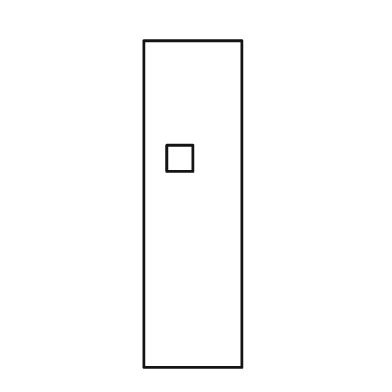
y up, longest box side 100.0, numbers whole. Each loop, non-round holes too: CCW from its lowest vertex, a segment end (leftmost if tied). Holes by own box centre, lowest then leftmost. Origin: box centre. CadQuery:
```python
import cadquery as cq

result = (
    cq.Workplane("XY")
    .moveTo(-15.0, -50.0)
    .lineTo(15.0, -50.0)
    .lineTo(15.0, 50.0)
    .lineTo(-15.0, 50.0)
    .close()
    .moveTo(-8.0, 10.0)
    .lineTo(0.0, 10.0)
    .lineTo(0.0, 18.0)
    .lineTo(-8.0, 18.0)
    .close()
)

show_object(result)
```